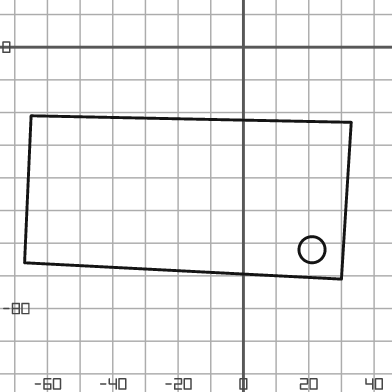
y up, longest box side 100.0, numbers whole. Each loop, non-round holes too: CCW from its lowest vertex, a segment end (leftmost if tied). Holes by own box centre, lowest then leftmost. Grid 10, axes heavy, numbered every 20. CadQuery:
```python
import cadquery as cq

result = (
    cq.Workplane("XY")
    .moveTo(30.0, -71.0)
    .lineTo(33.0, -23.0)
    .lineTo(-65.0, -21.0)
    .lineTo(-67.0, -66.0)
    .close()
    .moveTo(21.0, -62.0)
    .circle(4.0)
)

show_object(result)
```